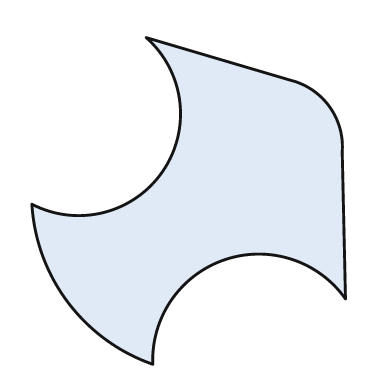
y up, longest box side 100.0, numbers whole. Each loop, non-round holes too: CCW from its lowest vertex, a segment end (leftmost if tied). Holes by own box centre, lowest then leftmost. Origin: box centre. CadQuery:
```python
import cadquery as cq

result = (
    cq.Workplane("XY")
    .moveTo(-11.0, -50.0)
    .threePointArc((11.0, -18.0), (48.0, -30.0))
    .lineTo(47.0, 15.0)
    .threePointArc((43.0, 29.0), (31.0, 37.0))
    .lineTo(-13.0, 50.0)
    .threePointArc((-8.0, 9.0), (-48.0, -1.0))
    .threePointArc((-37.0, -31.0), (-11.0, -50.0))
    .close()
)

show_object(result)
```